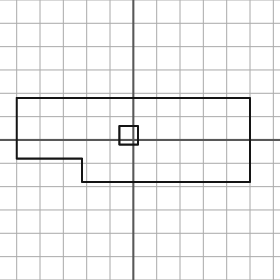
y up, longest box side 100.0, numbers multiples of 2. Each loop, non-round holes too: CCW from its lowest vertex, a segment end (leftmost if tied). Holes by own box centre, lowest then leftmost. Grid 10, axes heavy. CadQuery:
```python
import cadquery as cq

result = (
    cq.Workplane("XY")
    .moveTo(-22.0, -18.0)
    .lineTo(50.0, -18.0)
    .lineTo(50.0, 18.0)
    .lineTo(-50.0, 18.0)
    .lineTo(-50.0, -8.0)
    .lineTo(-22.0, -8.0)
    .close()
    .moveTo(-6.0, -2.0)
    .lineTo(2.0, -2.0)
    .lineTo(2.0, 6.0)
    .lineTo(-6.0, 6.0)
    .close()
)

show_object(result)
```